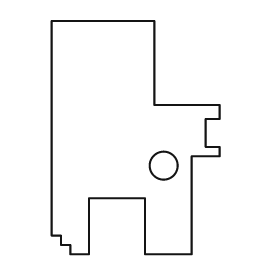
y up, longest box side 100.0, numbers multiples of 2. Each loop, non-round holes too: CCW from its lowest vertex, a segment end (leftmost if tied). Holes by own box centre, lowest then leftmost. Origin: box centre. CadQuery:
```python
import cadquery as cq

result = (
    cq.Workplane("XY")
    .moveTo(-28.0, -50.0)
    .lineTo(-20.0, -50.0)
    .lineTo(-20.0, -26.0)
    .lineTo(4.0, -26.0)
    .lineTo(4.0, -50.0)
    .lineTo(24.0, -50.0)
    .lineTo(24.0, -8.0)
    .lineTo(36.0, -8.0)
    .lineTo(36.0, -4.0)
    .lineTo(30.0, -4.0)
    .lineTo(30.0, 8.0)
    .lineTo(36.0, 8.0)
    .lineTo(36.0, 14.0)
    .lineTo(8.0, 14.0)
    .lineTo(8.0, 50.0)
    .lineTo(-36.0, 50.0)
    .lineTo(-36.0, -42.0)
    .lineTo(-32.0, -42.0)
    .lineTo(-32.0, -46.0)
    .lineTo(-28.0, -46.0)
    .close()
    .moveTo(12.0, -12.0)
    .circle(6.0)
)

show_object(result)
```